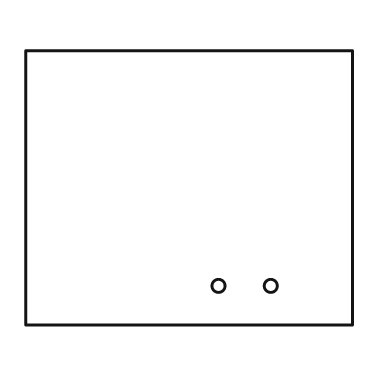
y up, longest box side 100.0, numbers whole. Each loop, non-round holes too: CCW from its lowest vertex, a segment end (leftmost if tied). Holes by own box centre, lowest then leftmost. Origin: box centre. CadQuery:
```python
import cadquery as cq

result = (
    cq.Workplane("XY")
    .moveTo(-50.0, -42.0)
    .lineTo(50.0, -42.0)
    .lineTo(50.0, 42.0)
    .lineTo(-50.0, 42.0)
    .close()
    .moveTo(9.0, -30.0)
    .circle(2.0)
    .moveTo(25.0, -30.0)
    .circle(2.0)
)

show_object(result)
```